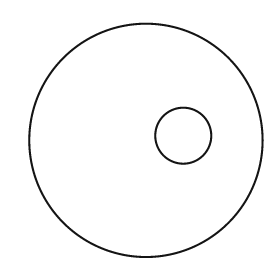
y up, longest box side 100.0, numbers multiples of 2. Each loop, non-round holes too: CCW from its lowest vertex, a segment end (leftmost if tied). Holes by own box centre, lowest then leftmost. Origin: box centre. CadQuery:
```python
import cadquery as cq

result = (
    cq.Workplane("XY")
    .moveTo(0.0, 0.0)
    .circle(50.0)
    .moveTo(16.0, 2.0)
    .circle(12.0)
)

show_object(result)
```